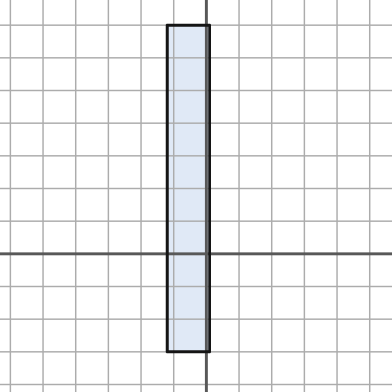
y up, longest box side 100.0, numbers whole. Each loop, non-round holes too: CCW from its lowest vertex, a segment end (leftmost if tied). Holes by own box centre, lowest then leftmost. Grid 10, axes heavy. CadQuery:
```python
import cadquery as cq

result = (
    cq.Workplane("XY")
    .moveTo(-12.0, -30.0)
    .lineTo(1.0, -30.0)
    .lineTo(1.0, 70.0)
    .lineTo(-12.0, 70.0)
    .close()
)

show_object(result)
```